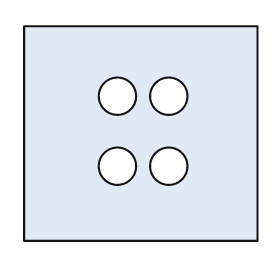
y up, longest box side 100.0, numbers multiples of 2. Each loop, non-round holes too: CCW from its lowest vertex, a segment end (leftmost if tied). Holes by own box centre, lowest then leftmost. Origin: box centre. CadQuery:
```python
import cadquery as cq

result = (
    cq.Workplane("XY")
    .moveTo(-50.0, -46.0)
    .lineTo(50.0, -46.0)
    .lineTo(50.0, 46.0)
    .lineTo(-50.0, 46.0)
    .close()
    .moveTo(-10.0, -14.0)
    .circle(8.0)
    .moveTo(12.0, -14.0)
    .circle(8.0)
    .moveTo(-10.0, 16.0)
    .circle(8.0)
    .moveTo(12.0, 16.0)
    .circle(8.0)
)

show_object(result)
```